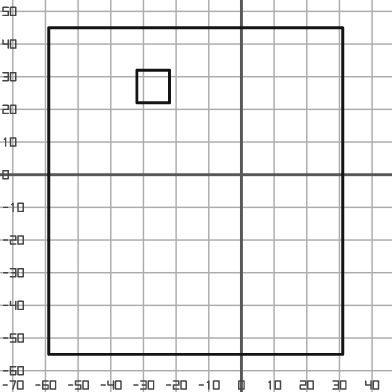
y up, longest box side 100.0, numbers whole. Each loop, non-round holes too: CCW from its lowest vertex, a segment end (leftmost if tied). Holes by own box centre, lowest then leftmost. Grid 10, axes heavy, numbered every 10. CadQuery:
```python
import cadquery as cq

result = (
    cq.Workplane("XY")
    .moveTo(-59.0, -55.0)
    .lineTo(31.0, -55.0)
    .lineTo(31.0, 45.0)
    .lineTo(-59.0, 45.0)
    .close()
    .moveTo(-32.0, 22.0)
    .lineTo(-22.0, 22.0)
    .lineTo(-22.0, 32.0)
    .lineTo(-32.0, 32.0)
    .close()
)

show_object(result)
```